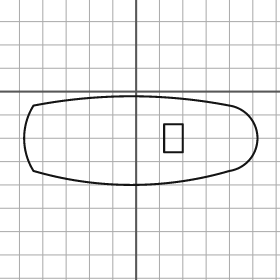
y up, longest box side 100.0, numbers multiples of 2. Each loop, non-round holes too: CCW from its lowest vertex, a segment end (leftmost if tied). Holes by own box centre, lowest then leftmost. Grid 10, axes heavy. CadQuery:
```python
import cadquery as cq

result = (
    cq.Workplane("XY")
    .moveTo(-44.0, -34.0)
    .threePointArc((-2.0, -40.0), (40.0, -34.0))
    .threePointArc((52.0, -20.0), (40.0, -6.0))
    .threePointArc((-2.0, -2.0), (-44.0, -6.0))
    .threePointArc((-48.0, -20.0), (-44.0, -34.0))
    .close()
    .moveTo(12.0, -26.0)
    .lineTo(20.0, -26.0)
    .lineTo(20.0, -14.0)
    .lineTo(12.0, -14.0)
    .close()
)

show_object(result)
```